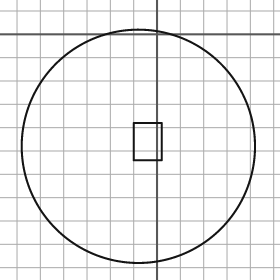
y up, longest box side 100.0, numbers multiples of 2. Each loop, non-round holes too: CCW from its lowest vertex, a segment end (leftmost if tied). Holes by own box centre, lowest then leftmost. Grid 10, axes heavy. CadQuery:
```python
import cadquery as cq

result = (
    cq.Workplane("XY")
    .moveTo(-8.0, -48.0)
    .circle(50.0)
    .moveTo(-10.0, -54.0)
    .lineTo(2.0, -54.0)
    .lineTo(2.0, -38.0)
    .lineTo(-10.0, -38.0)
    .close()
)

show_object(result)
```